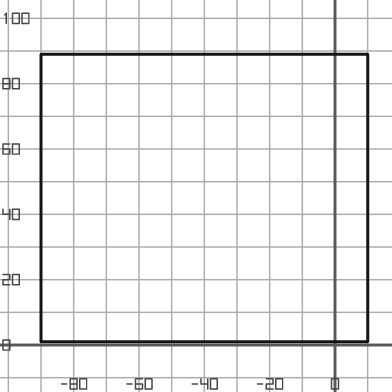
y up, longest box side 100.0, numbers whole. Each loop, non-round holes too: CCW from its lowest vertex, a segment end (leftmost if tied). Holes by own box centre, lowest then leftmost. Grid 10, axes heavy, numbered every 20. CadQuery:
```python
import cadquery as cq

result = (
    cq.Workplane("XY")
    .moveTo(-90.0, 1.0)
    .lineTo(10.0, 1.0)
    .lineTo(10.0, 89.0)
    .lineTo(-90.0, 89.0)
    .close()
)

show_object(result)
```